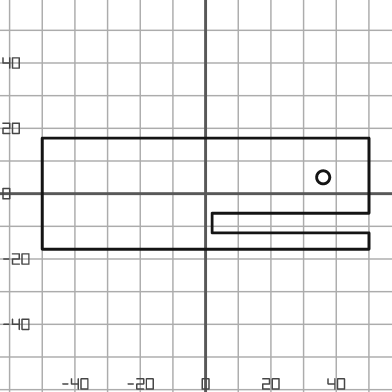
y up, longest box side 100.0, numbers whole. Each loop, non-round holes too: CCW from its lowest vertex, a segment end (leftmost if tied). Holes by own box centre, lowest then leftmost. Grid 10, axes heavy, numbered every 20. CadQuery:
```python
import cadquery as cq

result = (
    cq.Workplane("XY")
    .moveTo(-50.0, -17.0)
    .lineTo(50.0, -17.0)
    .lineTo(50.0, -12.0)
    .lineTo(2.0, -12.0)
    .lineTo(2.0, -6.0)
    .lineTo(50.0, -6.0)
    .lineTo(50.0, 17.0)
    .lineTo(-50.0, 17.0)
    .close()
    .moveTo(36.0, 5.0)
    .circle(2.0)
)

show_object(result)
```